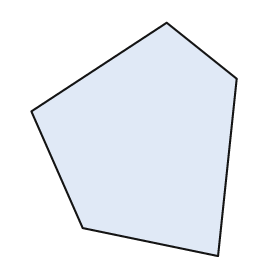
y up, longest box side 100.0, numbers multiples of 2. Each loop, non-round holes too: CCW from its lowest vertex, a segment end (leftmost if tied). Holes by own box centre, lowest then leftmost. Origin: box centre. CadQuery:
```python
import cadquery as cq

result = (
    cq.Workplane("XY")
    .moveTo(36.0, -50.0)
    .lineTo(44.0, 26.0)
    .lineTo(14.0, 50.0)
    .lineTo(-44.0, 12.0)
    .lineTo(-22.0, -38.0)
    .close()
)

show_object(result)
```